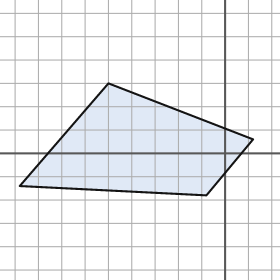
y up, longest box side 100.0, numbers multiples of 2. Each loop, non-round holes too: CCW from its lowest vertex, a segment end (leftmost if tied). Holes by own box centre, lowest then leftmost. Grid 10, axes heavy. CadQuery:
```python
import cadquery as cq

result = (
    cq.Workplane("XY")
    .moveTo(-8.0, -18.0)
    .lineTo(12.0, 6.0)
    .lineTo(-50.0, 30.0)
    .lineTo(-88.0, -14.0)
    .close()
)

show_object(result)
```